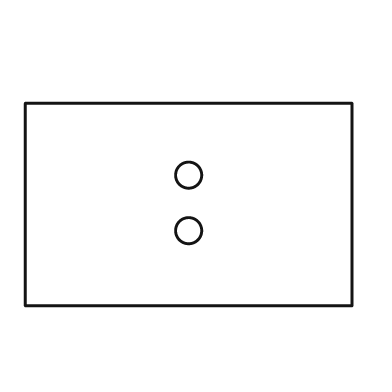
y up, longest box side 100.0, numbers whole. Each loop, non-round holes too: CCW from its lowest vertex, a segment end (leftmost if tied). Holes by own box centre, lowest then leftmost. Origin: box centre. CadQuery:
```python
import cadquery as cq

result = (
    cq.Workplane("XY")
    .moveTo(-50.0, -31.0)
    .lineTo(50.0, -31.0)
    .lineTo(50.0, 31.0)
    .lineTo(-50.0, 31.0)
    .close()
    .moveTo(0.0, -8.0)
    .circle(4.0)
    .moveTo(0.0, 9.0)
    .circle(4.0)
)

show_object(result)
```